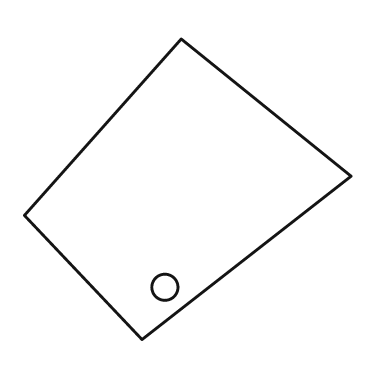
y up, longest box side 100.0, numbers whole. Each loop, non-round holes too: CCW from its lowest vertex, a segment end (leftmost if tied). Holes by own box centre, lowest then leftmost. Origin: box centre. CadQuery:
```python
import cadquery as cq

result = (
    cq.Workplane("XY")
    .moveTo(-14.0, -46.0)
    .lineTo(50.0, 4.0)
    .lineTo(-2.0, 46.0)
    .lineTo(-50.0, -8.0)
    .close()
    .moveTo(-7.0, -30.0)
    .circle(4.0)
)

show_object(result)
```